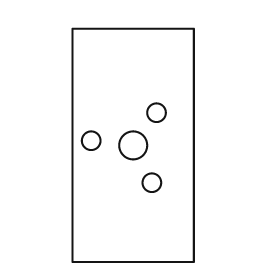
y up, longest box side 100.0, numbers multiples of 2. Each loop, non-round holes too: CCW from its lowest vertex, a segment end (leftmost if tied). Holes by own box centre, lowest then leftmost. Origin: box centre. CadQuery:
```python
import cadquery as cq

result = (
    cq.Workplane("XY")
    .moveTo(-26.0, -50.0)
    .lineTo(26.0, -50.0)
    .lineTo(26.0, 50.0)
    .lineTo(-26.0, 50.0)
    .close()
    .moveTo(8.0, -16.0)
    .circle(4.0)
    .moveTo(0.0, 0.0)
    .circle(6.0)
    .moveTo(-18.0, 2.0)
    .circle(4.0)
    .moveTo(10.0, 14.0)
    .circle(4.0)
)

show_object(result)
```